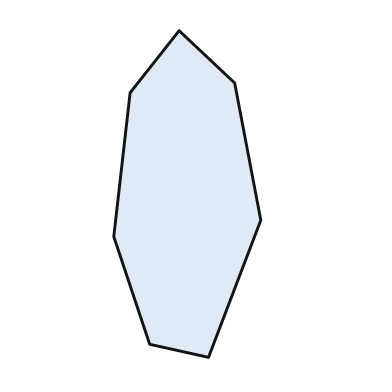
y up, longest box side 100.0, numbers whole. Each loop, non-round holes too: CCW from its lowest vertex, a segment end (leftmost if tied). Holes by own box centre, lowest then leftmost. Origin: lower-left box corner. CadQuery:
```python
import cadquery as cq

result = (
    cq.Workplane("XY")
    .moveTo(29.0, 0.0)
    .lineTo(45.0, 42.0)
    .lineTo(37.0, 84.0)
    .lineTo(20.0, 100.0)
    .lineTo(5.0, 81.0)
    .lineTo(0.0, 37.0)
    .lineTo(11.0, 4.0)
    .close()
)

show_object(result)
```